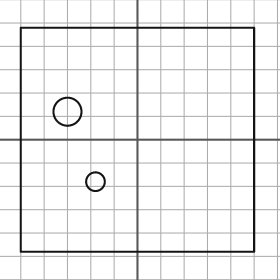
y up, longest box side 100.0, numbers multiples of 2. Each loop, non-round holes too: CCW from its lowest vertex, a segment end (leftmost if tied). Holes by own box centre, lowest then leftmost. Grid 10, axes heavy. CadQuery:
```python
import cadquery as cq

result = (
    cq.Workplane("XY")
    .moveTo(-50.0, -48.0)
    .lineTo(50.0, -48.0)
    .lineTo(50.0, 48.0)
    .lineTo(-50.0, 48.0)
    .close()
    .moveTo(-18.0, -18.0)
    .circle(4.0)
    .moveTo(-30.0, 12.0)
    .circle(6.0)
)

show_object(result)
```